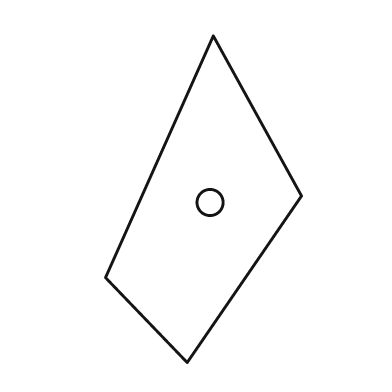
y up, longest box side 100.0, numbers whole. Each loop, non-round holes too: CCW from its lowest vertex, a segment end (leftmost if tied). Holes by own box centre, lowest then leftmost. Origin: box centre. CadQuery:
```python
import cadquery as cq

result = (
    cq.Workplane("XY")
    .moveTo(-5.0, -50.0)
    .lineTo(30.0, 1.0)
    .lineTo(3.0, 50.0)
    .lineTo(-30.0, -24.0)
    .close()
    .moveTo(2.0, -1.0)
    .circle(4.0)
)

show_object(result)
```